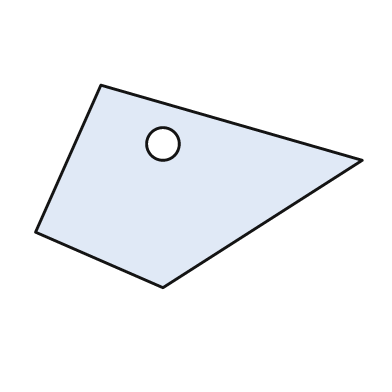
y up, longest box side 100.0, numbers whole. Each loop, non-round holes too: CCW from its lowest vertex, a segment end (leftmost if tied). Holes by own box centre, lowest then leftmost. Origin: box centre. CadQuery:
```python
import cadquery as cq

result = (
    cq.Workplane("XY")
    .moveTo(-11.0, -31.0)
    .lineTo(50.0, 8.0)
    .lineTo(-30.0, 31.0)
    .lineTo(-50.0, -14.0)
    .close()
    .moveTo(-11.0, 13.0)
    .circle(5.0)
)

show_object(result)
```